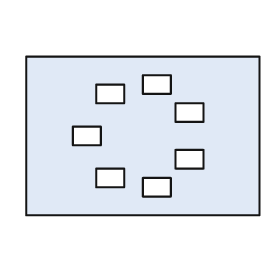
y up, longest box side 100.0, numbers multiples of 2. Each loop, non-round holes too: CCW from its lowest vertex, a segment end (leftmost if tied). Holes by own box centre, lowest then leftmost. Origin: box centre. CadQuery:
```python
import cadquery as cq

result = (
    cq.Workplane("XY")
    .moveTo(-50.0, -34.0)
    .lineTo(50.0, -34.0)
    .lineTo(50.0, 34.0)
    .lineTo(-50.0, 34.0)
    .close()
    .moveTo(0.0, -26.0)
    .lineTo(12.0, -26.0)
    .lineTo(12.0, -18.0)
    .lineTo(0.0, -18.0)
    .close()
    .moveTo(-20.0, -22.0)
    .lineTo(-8.0, -22.0)
    .lineTo(-8.0, -14.0)
    .lineTo(-20.0, -14.0)
    .close()
    .moveTo(14.0, -14.0)
    .lineTo(26.0, -14.0)
    .lineTo(26.0, -6.0)
    .lineTo(14.0, -6.0)
    .close()
    .moveTo(-30.0, -4.0)
    .lineTo(-18.0, -4.0)
    .lineTo(-18.0, 4.0)
    .lineTo(-30.0, 4.0)
    .close()
    .moveTo(14.0, 6.0)
    .lineTo(26.0, 6.0)
    .lineTo(26.0, 14.0)
    .lineTo(14.0, 14.0)
    .close()
    .moveTo(-20.0, 14.0)
    .lineTo(-8.0, 14.0)
    .lineTo(-8.0, 22.0)
    .lineTo(-20.0, 22.0)
    .close()
    .moveTo(0.0, 18.0)
    .lineTo(12.0, 18.0)
    .lineTo(12.0, 26.0)
    .lineTo(0.0, 26.0)
    .close()
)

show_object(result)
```